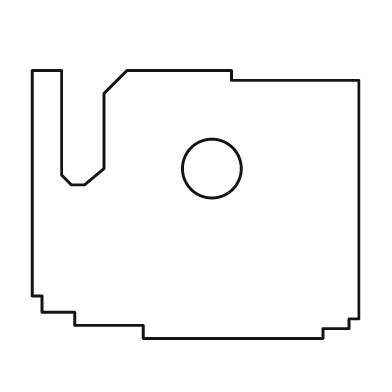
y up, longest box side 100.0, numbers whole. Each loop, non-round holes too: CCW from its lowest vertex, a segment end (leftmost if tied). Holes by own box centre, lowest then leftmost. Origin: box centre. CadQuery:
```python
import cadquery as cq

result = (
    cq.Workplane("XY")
    .moveTo(-16.0, -41.0)
    .lineTo(39.0, -41.0)
    .lineTo(39.0, -38.0)
    .lineTo(47.0, -38.0)
    .lineTo(47.0, -35.0)
    .lineTo(50.0, -35.0)
    .lineTo(50.0, 38.0)
    .lineTo(11.0, 38.0)
    .lineTo(11.0, 41.0)
    .lineTo(-21.0, 41.0)
    .lineTo(-28.0, 34.0)
    .lineTo(-28.0, 11.0)
    .lineTo(-34.0, 6.0)
    .lineTo(-38.0, 6.0)
    .lineTo(-41.0, 9.0)
    .lineTo(-41.0, 41.0)
    .lineTo(-50.0, 41.0)
    .lineTo(-50.0, -28.0)
    .lineTo(-47.0, -28.0)
    .lineTo(-47.0, -33.0)
    .lineTo(-37.0, -33.0)
    .lineTo(-37.0, -37.0)
    .lineTo(-16.0, -37.0)
    .close()
    .moveTo(5.0, 11.0)
    .circle(9.0)
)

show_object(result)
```